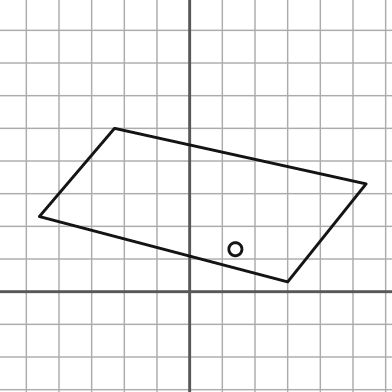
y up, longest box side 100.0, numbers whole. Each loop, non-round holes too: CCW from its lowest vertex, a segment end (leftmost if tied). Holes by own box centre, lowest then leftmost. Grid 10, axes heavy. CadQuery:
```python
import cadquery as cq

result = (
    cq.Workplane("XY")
    .moveTo(30.0, 3.0)
    .lineTo(54.0, 33.0)
    .lineTo(-23.0, 50.0)
    .lineTo(-46.0, 23.0)
    .close()
    .moveTo(14.0, 13.0)
    .circle(2.0)
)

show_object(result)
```